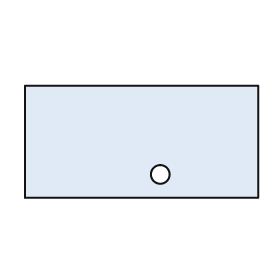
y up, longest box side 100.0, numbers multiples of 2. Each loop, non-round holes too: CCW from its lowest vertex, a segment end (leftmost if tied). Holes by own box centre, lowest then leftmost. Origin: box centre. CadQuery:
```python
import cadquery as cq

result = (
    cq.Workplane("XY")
    .moveTo(-50.0, -24.0)
    .lineTo(50.0, -24.0)
    .lineTo(50.0, 24.0)
    .lineTo(-50.0, 24.0)
    .close()
    .moveTo(8.0, -14.0)
    .circle(4.0)
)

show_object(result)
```